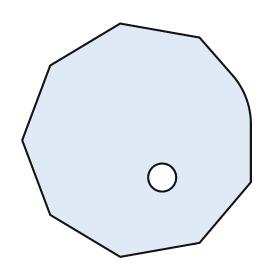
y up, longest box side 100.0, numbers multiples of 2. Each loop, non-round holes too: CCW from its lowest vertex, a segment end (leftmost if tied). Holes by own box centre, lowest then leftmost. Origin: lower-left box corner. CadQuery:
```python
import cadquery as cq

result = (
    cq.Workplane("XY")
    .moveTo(42.0, 0.0)
    .lineTo(76.0, 6.0)
    .lineTo(98.0, 32.0)
    .lineTo(98.0, 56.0)
    .threePointArc((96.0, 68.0), (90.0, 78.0))
    .lineTo(76.0, 94.0)
    .lineTo(42.0, 100.0)
    .lineTo(12.0, 82.0)
    .lineTo(0.0, 50.0)
    .lineTo(12.0, 18.0)
    .close()
    .moveTo(60.0, 34.0)
    .circle(6.0)
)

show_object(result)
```